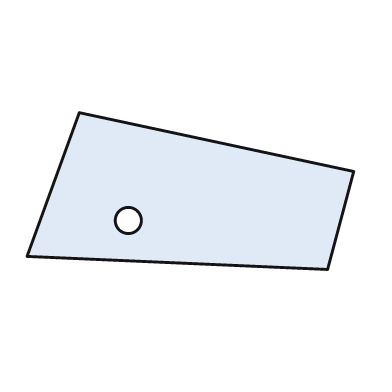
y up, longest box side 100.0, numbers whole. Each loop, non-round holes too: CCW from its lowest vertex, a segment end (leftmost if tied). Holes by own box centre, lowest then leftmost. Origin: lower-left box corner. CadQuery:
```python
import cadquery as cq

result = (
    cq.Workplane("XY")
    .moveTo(92.0, 0.0)
    .lineTo(100.0, 30.0)
    .lineTo(16.0, 48.0)
    .lineTo(0.0, 4.0)
    .close()
    .moveTo(31.0, 15.0)
    .circle(4.0)
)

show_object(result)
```